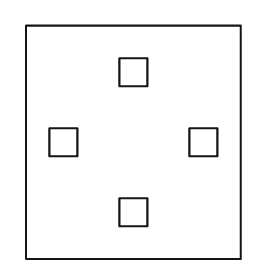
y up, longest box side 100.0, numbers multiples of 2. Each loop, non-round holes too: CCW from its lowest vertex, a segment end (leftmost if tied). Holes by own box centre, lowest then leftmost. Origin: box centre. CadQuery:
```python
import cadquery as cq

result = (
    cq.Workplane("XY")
    .moveTo(-46.0, -50.0)
    .lineTo(46.0, -50.0)
    .lineTo(46.0, 50.0)
    .lineTo(-46.0, 50.0)
    .close()
    .moveTo(-6.0, -36.0)
    .lineTo(6.0, -36.0)
    .lineTo(6.0, -24.0)
    .lineTo(-6.0, -24.0)
    .close()
    .moveTo(-36.0, -6.0)
    .lineTo(-24.0, -6.0)
    .lineTo(-24.0, 6.0)
    .lineTo(-36.0, 6.0)
    .close()
    .moveTo(24.0, -6.0)
    .lineTo(36.0, -6.0)
    .lineTo(36.0, 6.0)
    .lineTo(24.0, 6.0)
    .close()
    .moveTo(-6.0, 24.0)
    .lineTo(6.0, 24.0)
    .lineTo(6.0, 36.0)
    .lineTo(-6.0, 36.0)
    .close()
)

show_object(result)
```